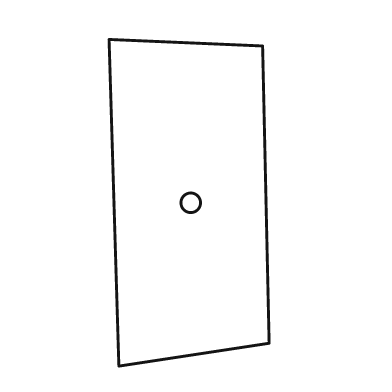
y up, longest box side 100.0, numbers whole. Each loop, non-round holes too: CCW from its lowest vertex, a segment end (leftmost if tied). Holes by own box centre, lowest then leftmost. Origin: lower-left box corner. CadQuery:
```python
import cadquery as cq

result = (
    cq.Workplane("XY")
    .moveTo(3.0, 0.0)
    .lineTo(49.0, 7.0)
    .lineTo(47.0, 98.0)
    .lineTo(0.0, 100.0)
    .close()
    .moveTo(25.0, 50.0)
    .circle(3.0)
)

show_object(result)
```